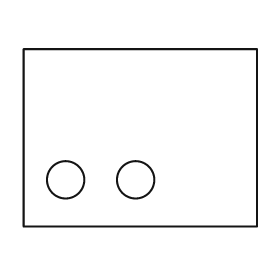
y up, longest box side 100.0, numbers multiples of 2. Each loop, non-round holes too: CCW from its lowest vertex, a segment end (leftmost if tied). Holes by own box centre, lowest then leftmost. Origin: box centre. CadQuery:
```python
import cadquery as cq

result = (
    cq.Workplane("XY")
    .moveTo(-50.0, -38.0)
    .lineTo(50.0, -38.0)
    .lineTo(50.0, 38.0)
    .lineTo(-50.0, 38.0)
    .close()
    .moveTo(-32.0, -18.0)
    .circle(8.0)
    .moveTo(-2.0, -18.0)
    .circle(8.0)
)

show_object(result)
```